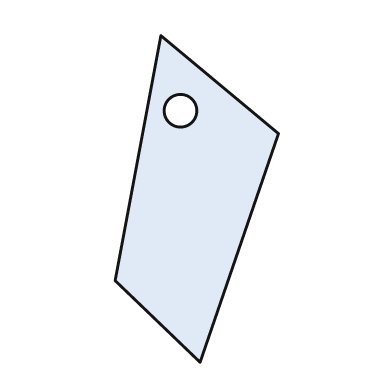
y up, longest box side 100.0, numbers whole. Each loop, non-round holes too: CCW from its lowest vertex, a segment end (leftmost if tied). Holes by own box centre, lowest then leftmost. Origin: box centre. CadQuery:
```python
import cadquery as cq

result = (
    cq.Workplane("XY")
    .moveTo(1.0, -50.0)
    .lineTo(25.0, 20.0)
    .lineTo(-11.0, 50.0)
    .lineTo(-25.0, -25.0)
    .close()
    .moveTo(-5.0, 27.0)
    .circle(5.0)
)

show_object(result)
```